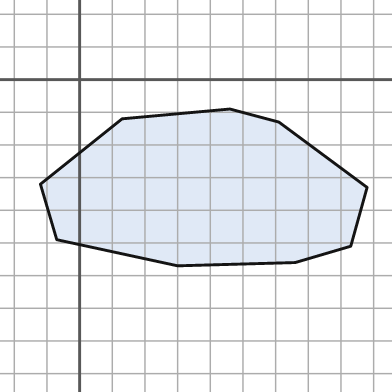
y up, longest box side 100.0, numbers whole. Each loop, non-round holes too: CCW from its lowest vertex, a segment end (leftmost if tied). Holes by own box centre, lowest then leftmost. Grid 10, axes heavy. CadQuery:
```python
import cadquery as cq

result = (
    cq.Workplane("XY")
    .moveTo(30.0, -57.0)
    .lineTo(66.0, -56.0)
    .lineTo(83.0, -51.0)
    .lineTo(88.0, -33.0)
    .lineTo(61.0, -13.0)
    .lineTo(46.0, -9.0)
    .lineTo(13.0, -12.0)
    .lineTo(-12.0, -32.0)
    .lineTo(-7.0, -49.0)
    .close()
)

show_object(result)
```